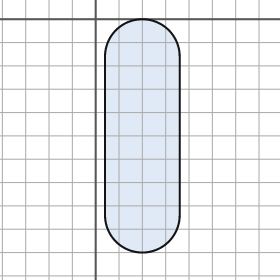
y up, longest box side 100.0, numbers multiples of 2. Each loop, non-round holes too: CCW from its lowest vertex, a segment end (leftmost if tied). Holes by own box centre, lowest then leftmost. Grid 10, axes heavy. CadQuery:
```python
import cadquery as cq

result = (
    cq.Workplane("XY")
    .moveTo(4.0, -84.0)
    .threePointArc((20.0, -100.0), (36.0, -84.0))
    .lineTo(36.0, -16.0)
    .threePointArc((20.0, 0.0), (4.0, -16.0))
    .close()
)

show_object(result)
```